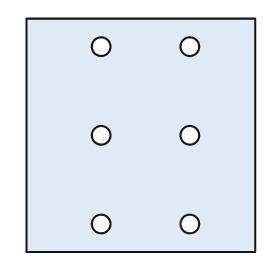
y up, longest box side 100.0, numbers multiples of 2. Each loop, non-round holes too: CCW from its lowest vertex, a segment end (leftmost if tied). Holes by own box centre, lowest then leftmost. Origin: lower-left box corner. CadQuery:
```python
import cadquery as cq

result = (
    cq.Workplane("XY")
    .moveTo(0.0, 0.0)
    .lineTo(98.0, 0.0)
    .lineTo(98.0, 100.0)
    .lineTo(0.0, 100.0)
    .close()
    .moveTo(32.0, 12.0)
    .circle(4.0)
    .moveTo(70.0, 12.0)
    .circle(4.0)
    .moveTo(32.0, 50.0)
    .circle(4.0)
    .moveTo(70.0, 50.0)
    .circle(4.0)
    .moveTo(32.0, 88.0)
    .circle(4.0)
    .moveTo(70.0, 88.0)
    .circle(4.0)
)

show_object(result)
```